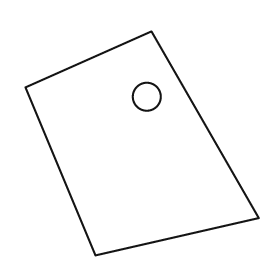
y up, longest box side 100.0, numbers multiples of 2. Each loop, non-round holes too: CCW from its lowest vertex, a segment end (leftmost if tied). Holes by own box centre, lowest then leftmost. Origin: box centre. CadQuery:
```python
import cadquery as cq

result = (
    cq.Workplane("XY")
    .moveTo(-20.0, -48.0)
    .lineTo(50.0, -32.0)
    .lineTo(4.0, 48.0)
    .lineTo(-50.0, 24.0)
    .close()
    .moveTo(2.0, 20.0)
    .circle(6.0)
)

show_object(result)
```